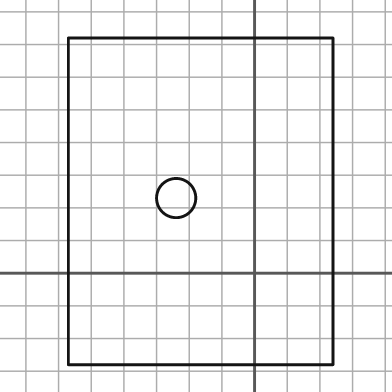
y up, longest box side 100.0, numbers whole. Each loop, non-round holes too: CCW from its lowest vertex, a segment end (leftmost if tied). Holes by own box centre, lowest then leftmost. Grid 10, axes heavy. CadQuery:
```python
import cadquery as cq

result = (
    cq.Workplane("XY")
    .moveTo(-57.0, -28.0)
    .lineTo(24.0, -28.0)
    .lineTo(24.0, 72.0)
    .lineTo(-57.0, 72.0)
    .close()
    .moveTo(-24.0, 23.0)
    .circle(6.0)
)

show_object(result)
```